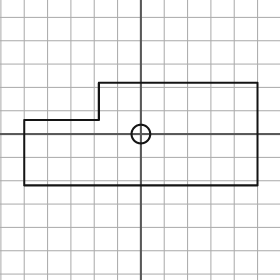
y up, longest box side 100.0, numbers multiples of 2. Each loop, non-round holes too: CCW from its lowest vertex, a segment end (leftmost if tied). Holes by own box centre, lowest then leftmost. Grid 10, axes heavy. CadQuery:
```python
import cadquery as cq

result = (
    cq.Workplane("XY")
    .moveTo(-50.0, -22.0)
    .lineTo(50.0, -22.0)
    .lineTo(50.0, 22.0)
    .lineTo(-18.0, 22.0)
    .lineTo(-18.0, 6.0)
    .lineTo(-50.0, 6.0)
    .close()
    .moveTo(0.0, 0.0)
    .circle(4.0)
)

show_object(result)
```